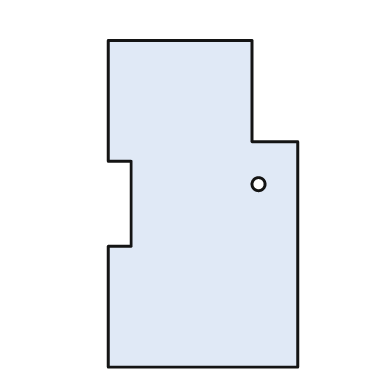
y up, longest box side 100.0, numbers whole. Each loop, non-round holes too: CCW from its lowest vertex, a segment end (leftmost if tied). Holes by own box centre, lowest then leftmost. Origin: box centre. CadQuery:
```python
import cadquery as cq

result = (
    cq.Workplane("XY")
    .moveTo(-29.0, -50.0)
    .lineTo(29.0, -50.0)
    .lineTo(29.0, 19.0)
    .lineTo(15.0, 19.0)
    .lineTo(15.0, 50.0)
    .lineTo(-29.0, 50.0)
    .lineTo(-29.0, 13.0)
    .lineTo(-22.0, 13.0)
    .lineTo(-22.0, -13.0)
    .lineTo(-29.0, -13.0)
    .close()
    .moveTo(17.0, 6.0)
    .circle(2.0)
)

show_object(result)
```